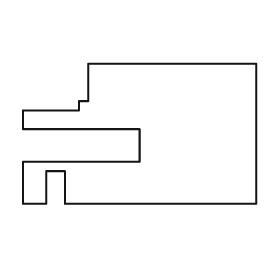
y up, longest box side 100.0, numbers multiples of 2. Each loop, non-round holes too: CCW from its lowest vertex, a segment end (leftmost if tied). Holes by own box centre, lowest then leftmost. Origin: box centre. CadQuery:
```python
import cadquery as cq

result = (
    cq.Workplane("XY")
    .moveTo(-50.0, -30.0)
    .lineTo(-40.0, -30.0)
    .lineTo(-40.0, -16.0)
    .lineTo(-32.0, -16.0)
    .lineTo(-32.0, -30.0)
    .lineTo(50.0, -30.0)
    .lineTo(50.0, 30.0)
    .lineTo(-22.0, 30.0)
    .lineTo(-22.0, 14.0)
    .lineTo(-26.0, 14.0)
    .lineTo(-26.0, 10.0)
    .lineTo(-50.0, 10.0)
    .lineTo(-50.0, 2.0)
    .lineTo(0.0, 2.0)
    .lineTo(0.0, -12.0)
    .lineTo(-50.0, -12.0)
    .close()
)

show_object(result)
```